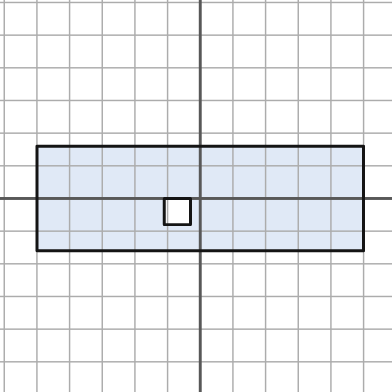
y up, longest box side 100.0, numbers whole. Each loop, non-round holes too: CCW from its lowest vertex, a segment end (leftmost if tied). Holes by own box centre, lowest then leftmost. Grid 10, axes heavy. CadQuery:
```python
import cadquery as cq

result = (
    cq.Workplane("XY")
    .moveTo(-50.0, -16.0)
    .lineTo(50.0, -16.0)
    .lineTo(50.0, 16.0)
    .lineTo(-50.0, 16.0)
    .close()
    .moveTo(-11.0, -8.0)
    .lineTo(-3.0, -8.0)
    .lineTo(-3.0, 0.0)
    .lineTo(-11.0, 0.0)
    .close()
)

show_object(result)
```